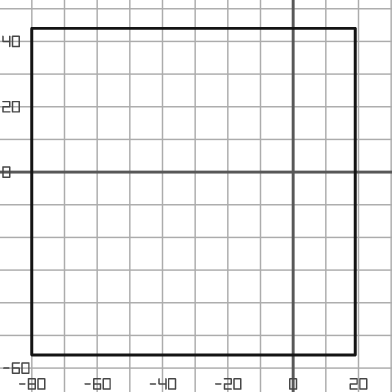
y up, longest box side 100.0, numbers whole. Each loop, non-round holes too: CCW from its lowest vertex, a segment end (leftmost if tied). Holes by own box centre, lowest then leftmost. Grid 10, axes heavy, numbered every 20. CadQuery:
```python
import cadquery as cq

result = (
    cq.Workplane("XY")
    .moveTo(-80.0, -56.0)
    .lineTo(19.0, -56.0)
    .lineTo(19.0, 44.0)
    .lineTo(-80.0, 44.0)
    .close()
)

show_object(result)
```